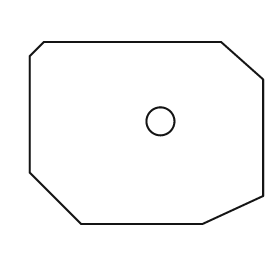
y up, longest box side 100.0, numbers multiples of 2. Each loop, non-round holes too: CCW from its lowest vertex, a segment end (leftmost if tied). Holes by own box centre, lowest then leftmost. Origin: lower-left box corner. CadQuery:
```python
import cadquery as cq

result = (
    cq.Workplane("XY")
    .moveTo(22.0, 0.0)
    .lineTo(74.0, 0.0)
    .lineTo(100.0, 12.0)
    .lineTo(100.0, 62.0)
    .lineTo(82.0, 78.0)
    .lineTo(6.0, 78.0)
    .lineTo(0.0, 72.0)
    .lineTo(0.0, 22.0)
    .close()
    .moveTo(56.0, 44.0)
    .circle(6.0)
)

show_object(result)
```